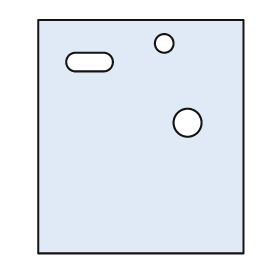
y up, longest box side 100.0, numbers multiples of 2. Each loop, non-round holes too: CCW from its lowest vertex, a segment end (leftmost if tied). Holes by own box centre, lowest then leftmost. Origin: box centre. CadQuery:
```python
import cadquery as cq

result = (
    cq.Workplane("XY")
    .moveTo(-44.0, -50.0)
    .lineTo(44.0, -50.0)
    .lineTo(44.0, 50.0)
    .lineTo(-44.0, 50.0)
    .close()
    .moveTo(20.0, 6.0)
    .circle(6.0)
    .moveTo(-28.0, 28.0)
    .lineTo(-16.0, 28.0)
    .threePointArc((-12.0, 32.0), (-16.0, 36.0))
    .lineTo(-28.0, 36.0)
    .threePointArc((-32.0, 32.0), (-28.0, 28.0))
    .close()
    .moveTo(10.0, 40.0)
    .circle(4.0)
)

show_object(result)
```